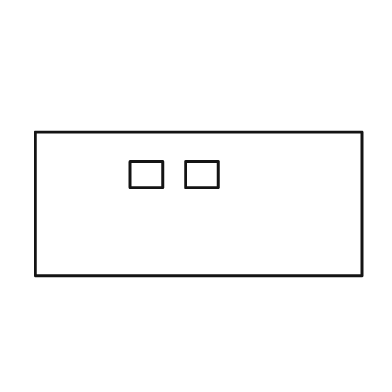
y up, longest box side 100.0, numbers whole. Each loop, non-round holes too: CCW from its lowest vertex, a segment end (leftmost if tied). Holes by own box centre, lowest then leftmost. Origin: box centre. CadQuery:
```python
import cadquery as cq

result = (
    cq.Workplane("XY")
    .moveTo(-50.0, -22.0)
    .lineTo(50.0, -22.0)
    .lineTo(50.0, 22.0)
    .lineTo(-50.0, 22.0)
    .close()
    .moveTo(-21.0, 5.0)
    .lineTo(-11.0, 5.0)
    .lineTo(-11.0, 13.0)
    .lineTo(-21.0, 13.0)
    .close()
    .moveTo(-4.0, 5.0)
    .lineTo(6.0, 5.0)
    .lineTo(6.0, 13.0)
    .lineTo(-4.0, 13.0)
    .close()
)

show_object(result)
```